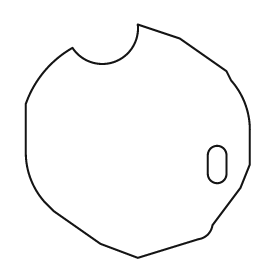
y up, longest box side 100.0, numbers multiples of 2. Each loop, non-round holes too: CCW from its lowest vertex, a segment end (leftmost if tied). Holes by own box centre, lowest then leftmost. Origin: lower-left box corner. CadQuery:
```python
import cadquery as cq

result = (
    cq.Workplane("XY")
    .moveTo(48.0, 0.0)
    .lineTo(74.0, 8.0)
    .threePointArc((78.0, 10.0), (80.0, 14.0))
    .lineTo(92.0, 30.0)
    .lineTo(96.0, 40.0)
    .lineTo(96.0, 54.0)
    .threePointArc((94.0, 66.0), (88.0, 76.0))
    .lineTo(86.0, 80.0)
    .lineTo(66.0, 94.0)
    .lineTo(48.0, 100.0)
    .threePointArc((38.0, 84.0), (20.0, 90.0))
    .threePointArc((8.0, 80.0), (0.0, 66.0))
    .lineTo(0.0, 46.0)
    .threePointArc((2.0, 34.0), (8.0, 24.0))
    .lineTo(12.0, 20.0)
    .lineTo(32.0, 6.0)
    .close()
    .moveTo(78.0, 36.0)
    .threePointArc((82.0, 32.0), (86.0, 36.0))
    .lineTo(86.0, 44.0)
    .threePointArc((82.0, 48.0), (78.0, 44.0))
    .close()
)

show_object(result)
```